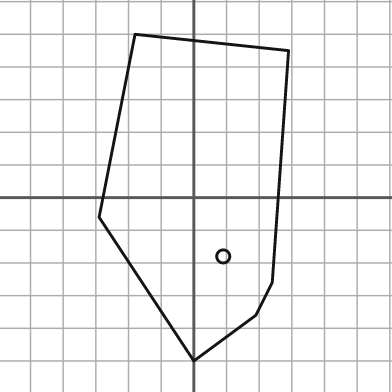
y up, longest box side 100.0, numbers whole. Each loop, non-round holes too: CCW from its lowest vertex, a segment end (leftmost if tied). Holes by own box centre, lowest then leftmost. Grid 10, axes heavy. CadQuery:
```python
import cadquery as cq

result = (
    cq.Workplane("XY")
    .moveTo(0.0, -50.0)
    .lineTo(19.0, -36.0)
    .lineTo(24.0, -26.0)
    .lineTo(29.0, 45.0)
    .lineTo(-18.0, 50.0)
    .lineTo(-29.0, -6.0)
    .close()
    .moveTo(9.0, -18.0)
    .circle(2.0)
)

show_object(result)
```